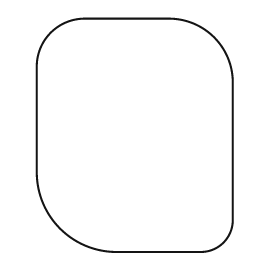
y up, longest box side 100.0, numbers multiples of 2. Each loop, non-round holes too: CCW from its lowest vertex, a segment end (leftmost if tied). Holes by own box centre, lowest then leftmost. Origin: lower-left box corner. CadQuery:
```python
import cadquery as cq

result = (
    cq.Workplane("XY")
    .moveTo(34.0, 0.0)
    .lineTo(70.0, 0.0)
    .threePointArc((80.0, 4.0), (84.0, 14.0))
    .lineTo(84.0, 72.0)
    .threePointArc((76.0, 92.0), (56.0, 100.0))
    .lineTo(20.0, 100.0)
    .threePointArc((6.0, 94.0), (0.0, 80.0))
    .lineTo(0.0, 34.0)
    .threePointArc((10.0, 10.0), (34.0, 0.0))
    .close()
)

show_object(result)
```